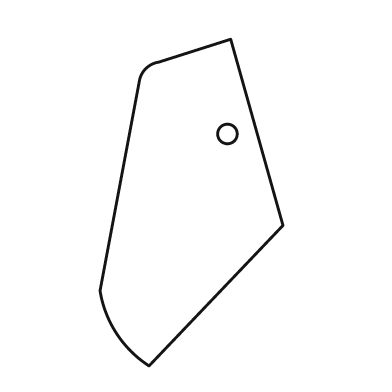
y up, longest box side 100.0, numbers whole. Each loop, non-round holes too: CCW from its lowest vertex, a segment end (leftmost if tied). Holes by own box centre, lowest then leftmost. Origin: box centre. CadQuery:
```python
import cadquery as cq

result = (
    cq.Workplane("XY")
    .moveTo(-13.0, -50.0)
    .lineTo(28.0, -7.0)
    .lineTo(12.0, 50.0)
    .lineTo(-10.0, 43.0)
    .threePointArc((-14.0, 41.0), (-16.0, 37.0))
    .lineTo(-28.0, -27.0)
    .threePointArc((-23.0, -40.0), (-13.0, -50.0))
    .close()
    .moveTo(11.0, 21.0)
    .circle(3.0)
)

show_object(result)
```